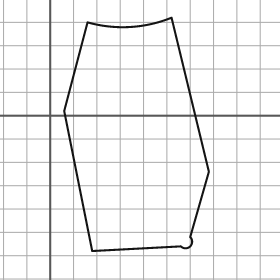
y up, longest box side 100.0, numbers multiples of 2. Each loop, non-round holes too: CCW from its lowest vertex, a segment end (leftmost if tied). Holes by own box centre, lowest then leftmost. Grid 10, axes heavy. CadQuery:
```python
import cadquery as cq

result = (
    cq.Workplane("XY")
    .moveTo(18.0, -58.0)
    .lineTo(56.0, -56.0)
    .threePointArc((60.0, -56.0), (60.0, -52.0))
    .lineTo(68.0, -24.0)
    .lineTo(52.0, 42.0)
    .threePointArc((34.0, 38.0), (16.0, 40.0))
    .lineTo(6.0, 2.0)
    .close()
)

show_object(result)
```